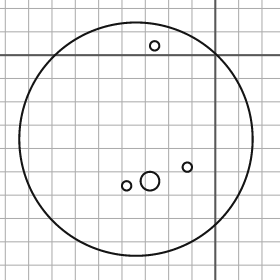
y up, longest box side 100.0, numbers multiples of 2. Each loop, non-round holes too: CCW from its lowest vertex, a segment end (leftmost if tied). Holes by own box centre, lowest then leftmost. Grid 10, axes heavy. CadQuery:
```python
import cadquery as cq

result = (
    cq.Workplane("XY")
    .moveTo(-34.0, -36.0)
    .circle(50.0)
    .moveTo(-38.0, -56.0)
    .circle(2.0)
    .moveTo(-28.0, -54.0)
    .circle(4.0)
    .moveTo(-12.0, -48.0)
    .circle(2.0)
    .moveTo(-26.0, 4.0)
    .circle(2.0)
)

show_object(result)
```